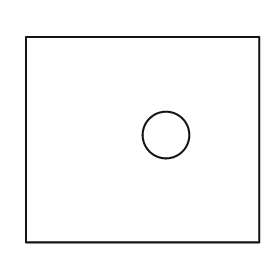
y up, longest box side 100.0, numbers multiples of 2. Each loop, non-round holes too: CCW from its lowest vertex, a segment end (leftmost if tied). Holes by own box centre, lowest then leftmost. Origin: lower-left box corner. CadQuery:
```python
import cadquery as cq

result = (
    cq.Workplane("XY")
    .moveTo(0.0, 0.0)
    .lineTo(100.0, 0.0)
    .lineTo(100.0, 88.0)
    .lineTo(0.0, 88.0)
    .close()
    .moveTo(60.0, 46.0)
    .circle(10.0)
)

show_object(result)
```